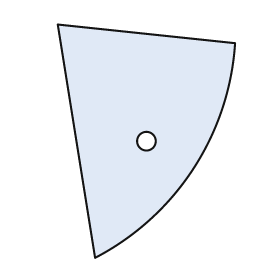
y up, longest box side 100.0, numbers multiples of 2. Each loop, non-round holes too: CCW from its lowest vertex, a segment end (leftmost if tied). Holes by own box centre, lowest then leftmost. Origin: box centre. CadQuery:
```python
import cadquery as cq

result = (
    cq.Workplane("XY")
    .moveTo(-22.0, -50.0)
    .threePointArc((20.0, -12.0), (38.0, 42.0))
    .lineTo(-38.0, 50.0)
    .close()
    .moveTo(0.0, 0.0)
    .circle(4.0)
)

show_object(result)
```